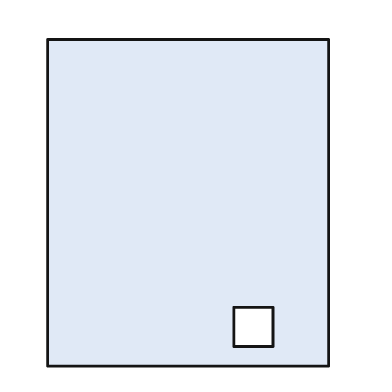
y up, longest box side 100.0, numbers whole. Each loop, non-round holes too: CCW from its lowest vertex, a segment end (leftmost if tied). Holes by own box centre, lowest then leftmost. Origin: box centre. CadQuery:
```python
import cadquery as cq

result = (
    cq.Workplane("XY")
    .moveTo(-43.0, -50.0)
    .lineTo(43.0, -50.0)
    .lineTo(43.0, 50.0)
    .lineTo(-43.0, 50.0)
    .close()
    .moveTo(14.0, -44.0)
    .lineTo(26.0, -44.0)
    .lineTo(26.0, -32.0)
    .lineTo(14.0, -32.0)
    .close()
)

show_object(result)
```